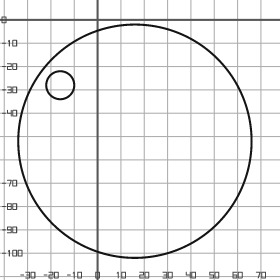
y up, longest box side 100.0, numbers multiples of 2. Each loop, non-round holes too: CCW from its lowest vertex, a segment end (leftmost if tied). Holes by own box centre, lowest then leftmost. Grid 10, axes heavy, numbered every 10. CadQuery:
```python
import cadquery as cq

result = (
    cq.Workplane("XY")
    .moveTo(16.0, -52.0)
    .circle(50.0)
    .moveTo(-16.0, -28.0)
    .circle(6.0)
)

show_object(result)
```